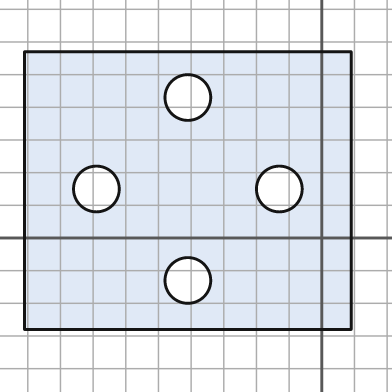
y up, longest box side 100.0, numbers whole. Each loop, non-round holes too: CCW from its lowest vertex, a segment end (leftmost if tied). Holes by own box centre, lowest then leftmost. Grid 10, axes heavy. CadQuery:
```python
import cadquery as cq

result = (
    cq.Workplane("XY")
    .moveTo(-91.0, -28.0)
    .lineTo(9.0, -28.0)
    .lineTo(9.0, 57.0)
    .lineTo(-91.0, 57.0)
    .close()
    .moveTo(-41.0, -13.0)
    .circle(7.0)
    .moveTo(-69.0, 15.0)
    .circle(7.0)
    .moveTo(-13.0, 15.0)
    .circle(7.0)
    .moveTo(-41.0, 43.0)
    .circle(7.0)
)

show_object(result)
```